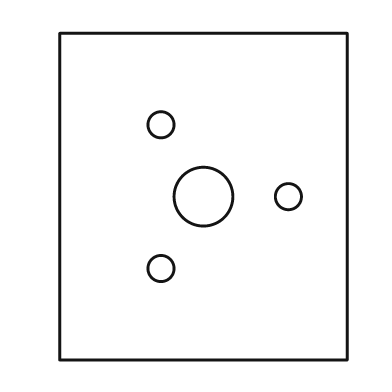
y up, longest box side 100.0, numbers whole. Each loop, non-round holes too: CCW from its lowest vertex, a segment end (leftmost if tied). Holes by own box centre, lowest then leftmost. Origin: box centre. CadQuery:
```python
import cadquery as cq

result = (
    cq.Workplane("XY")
    .moveTo(-44.0, -50.0)
    .lineTo(44.0, -50.0)
    .lineTo(44.0, 50.0)
    .lineTo(-44.0, 50.0)
    .close()
    .moveTo(-13.0, -22.0)
    .circle(4.0)
    .moveTo(0.0, 0.0)
    .circle(9.0)
    .moveTo(26.0, 0.0)
    .circle(4.0)
    .moveTo(-13.0, 22.0)
    .circle(4.0)
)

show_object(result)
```